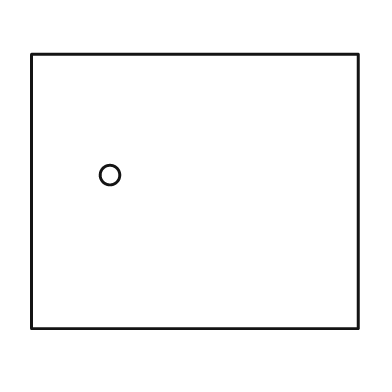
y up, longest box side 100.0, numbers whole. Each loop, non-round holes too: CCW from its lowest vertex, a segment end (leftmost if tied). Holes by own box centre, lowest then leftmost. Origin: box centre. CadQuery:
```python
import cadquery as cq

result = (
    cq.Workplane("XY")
    .moveTo(-50.0, -42.0)
    .lineTo(50.0, -42.0)
    .lineTo(50.0, 42.0)
    .lineTo(-50.0, 42.0)
    .close()
    .moveTo(-26.0, 5.0)
    .circle(3.0)
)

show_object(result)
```